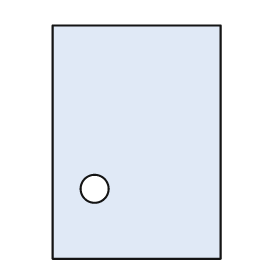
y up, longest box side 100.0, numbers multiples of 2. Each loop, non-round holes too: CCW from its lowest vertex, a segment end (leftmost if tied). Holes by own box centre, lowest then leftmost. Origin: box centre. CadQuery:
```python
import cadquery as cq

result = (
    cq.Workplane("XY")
    .moveTo(-36.0, -50.0)
    .lineTo(36.0, -50.0)
    .lineTo(36.0, 50.0)
    .lineTo(-36.0, 50.0)
    .close()
    .moveTo(-18.0, -20.0)
    .circle(6.0)
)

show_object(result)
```